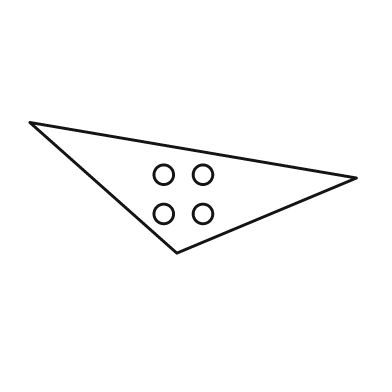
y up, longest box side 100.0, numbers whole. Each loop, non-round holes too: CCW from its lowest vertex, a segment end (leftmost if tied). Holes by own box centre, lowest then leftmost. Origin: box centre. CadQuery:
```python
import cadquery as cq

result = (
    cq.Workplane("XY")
    .moveTo(-5.0, -20.0)
    .lineTo(50.0, 3.0)
    .lineTo(-50.0, 20.0)
    .close()
    .moveTo(-9.0, -8.0)
    .circle(3.0)
    .moveTo(3.0, -8.0)
    .circle(3.0)
    .moveTo(-9.0, 4.0)
    .circle(3.0)
    .moveTo(3.0, 4.0)
    .circle(3.0)
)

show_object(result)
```